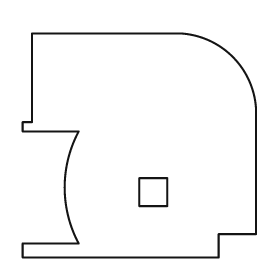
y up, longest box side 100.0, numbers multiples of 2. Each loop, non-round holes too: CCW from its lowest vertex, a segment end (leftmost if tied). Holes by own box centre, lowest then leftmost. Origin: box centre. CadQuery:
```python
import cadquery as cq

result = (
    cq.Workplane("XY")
    .moveTo(-50.0, -48.0)
    .lineTo(34.0, -48.0)
    .lineTo(34.0, -38.0)
    .lineTo(50.0, -38.0)
    .lineTo(50.0, 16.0)
    .threePointArc((40.0, 38.0), (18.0, 48.0))
    .lineTo(-46.0, 48.0)
    .lineTo(-46.0, 10.0)
    .lineTo(-50.0, 10.0)
    .lineTo(-50.0, 6.0)
    .lineTo(-26.0, 6.0)
    .threePointArc((-32.0, -18.0), (-26.0, -42.0))
    .lineTo(-50.0, -42.0)
    .close()
    .moveTo(0.0, -26.0)
    .lineTo(12.0, -26.0)
    .lineTo(12.0, -14.0)
    .lineTo(0.0, -14.0)
    .close()
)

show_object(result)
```